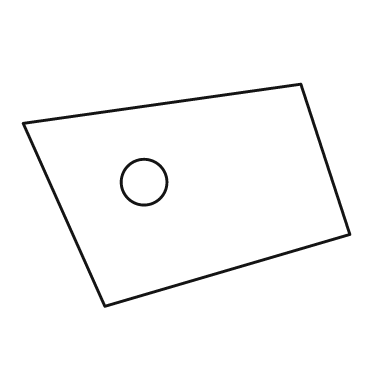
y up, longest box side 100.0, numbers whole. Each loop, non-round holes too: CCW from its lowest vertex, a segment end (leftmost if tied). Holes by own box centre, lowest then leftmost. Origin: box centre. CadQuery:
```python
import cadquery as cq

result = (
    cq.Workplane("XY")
    .moveTo(-25.0, -34.0)
    .lineTo(50.0, -12.0)
    .lineTo(35.0, 34.0)
    .lineTo(-50.0, 22.0)
    .close()
    .moveTo(-13.0, 4.0)
    .circle(7.0)
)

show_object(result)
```